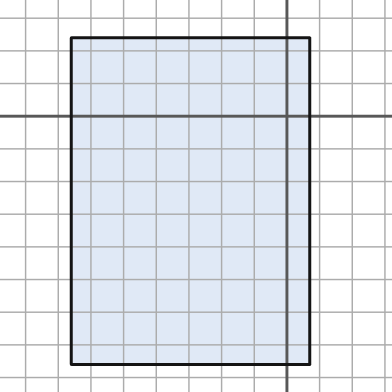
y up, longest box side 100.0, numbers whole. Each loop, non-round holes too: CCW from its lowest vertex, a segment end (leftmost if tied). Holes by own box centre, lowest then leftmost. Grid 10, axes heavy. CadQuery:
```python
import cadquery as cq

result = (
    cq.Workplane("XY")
    .moveTo(-66.0, -76.0)
    .lineTo(7.0, -76.0)
    .lineTo(7.0, 24.0)
    .lineTo(-66.0, 24.0)
    .close()
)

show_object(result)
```